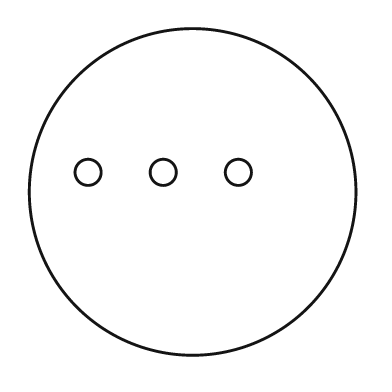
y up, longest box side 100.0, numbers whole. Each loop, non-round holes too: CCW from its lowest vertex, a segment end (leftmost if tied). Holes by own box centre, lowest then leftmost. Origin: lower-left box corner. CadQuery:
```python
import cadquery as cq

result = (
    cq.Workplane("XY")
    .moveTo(50.0, 50.0)
    .circle(50.0)
    .moveTo(18.0, 56.0)
    .circle(4.0)
    .moveTo(41.0, 56.0)
    .circle(4.0)
    .moveTo(64.0, 56.0)
    .circle(4.0)
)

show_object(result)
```